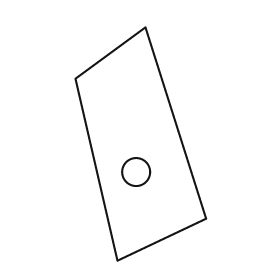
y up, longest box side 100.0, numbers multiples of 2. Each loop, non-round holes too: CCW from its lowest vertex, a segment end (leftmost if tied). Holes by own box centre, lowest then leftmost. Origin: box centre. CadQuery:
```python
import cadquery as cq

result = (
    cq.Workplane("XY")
    .moveTo(-10.0, -50.0)
    .lineTo(28.0, -32.0)
    .lineTo(2.0, 50.0)
    .lineTo(-28.0, 28.0)
    .close()
    .moveTo(-2.0, -12.0)
    .circle(6.0)
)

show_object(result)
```